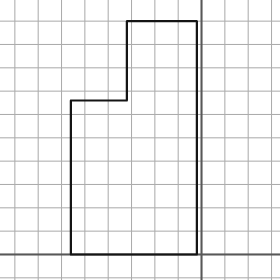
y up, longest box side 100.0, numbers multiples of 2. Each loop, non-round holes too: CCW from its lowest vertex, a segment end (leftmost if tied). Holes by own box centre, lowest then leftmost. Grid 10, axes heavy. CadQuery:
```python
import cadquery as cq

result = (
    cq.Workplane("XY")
    .moveTo(-56.0, 0.0)
    .lineTo(-2.0, 0.0)
    .lineTo(-2.0, 100.0)
    .lineTo(-32.0, 100.0)
    .lineTo(-32.0, 66.0)
    .lineTo(-56.0, 66.0)
    .close()
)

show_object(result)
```